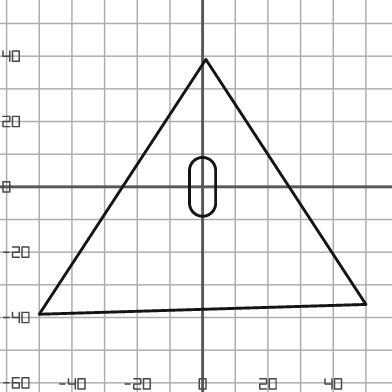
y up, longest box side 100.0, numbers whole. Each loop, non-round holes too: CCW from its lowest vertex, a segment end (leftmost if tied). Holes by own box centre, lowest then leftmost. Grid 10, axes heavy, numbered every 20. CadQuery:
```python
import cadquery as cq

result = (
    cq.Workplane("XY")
    .moveTo(-50.0, -39.0)
    .lineTo(50.0, -36.0)
    .lineTo(1.0, 39.0)
    .close()
    .moveTo(-4.0, -5.0)
    .threePointArc((0.0, -9.0), (4.0, -5.0))
    .lineTo(4.0, 5.0)
    .threePointArc((0.0, 9.0), (-4.0, 5.0))
    .close()
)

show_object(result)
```